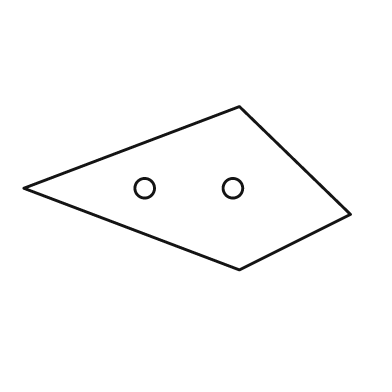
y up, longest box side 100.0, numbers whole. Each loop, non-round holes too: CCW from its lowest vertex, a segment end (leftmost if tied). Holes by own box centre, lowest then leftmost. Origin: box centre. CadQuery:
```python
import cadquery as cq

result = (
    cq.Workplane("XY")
    .moveTo(16.0, -25.0)
    .lineTo(50.0, -8.0)
    .lineTo(16.0, 25.0)
    .lineTo(-50.0, 0.0)
    .close()
    .moveTo(-13.0, 0.0)
    .circle(3.0)
    .moveTo(14.0, 0.0)
    .circle(3.0)
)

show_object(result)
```